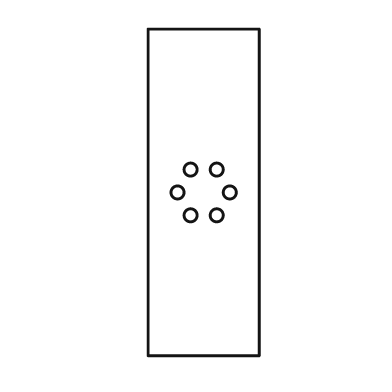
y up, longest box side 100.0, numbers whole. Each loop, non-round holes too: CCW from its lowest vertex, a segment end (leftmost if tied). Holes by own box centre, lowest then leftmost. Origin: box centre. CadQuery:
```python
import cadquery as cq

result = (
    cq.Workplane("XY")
    .moveTo(-17.0, -50.0)
    .lineTo(17.0, -50.0)
    .lineTo(17.0, 50.0)
    .lineTo(-17.0, 50.0)
    .close()
    .moveTo(-4.0, -7.0)
    .circle(2.0)
    .moveTo(4.0, -7.0)
    .circle(2.0)
    .moveTo(-8.0, 0.0)
    .circle(2.0)
    .moveTo(8.0, 0.0)
    .circle(2.0)
    .moveTo(-4.0, 7.0)
    .circle(2.0)
    .moveTo(4.0, 7.0)
    .circle(2.0)
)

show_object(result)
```